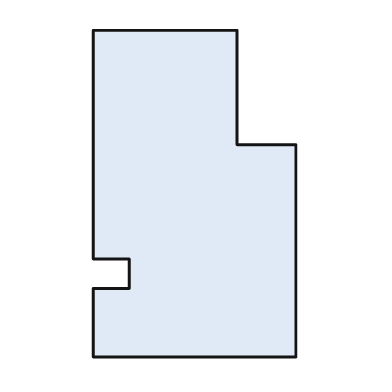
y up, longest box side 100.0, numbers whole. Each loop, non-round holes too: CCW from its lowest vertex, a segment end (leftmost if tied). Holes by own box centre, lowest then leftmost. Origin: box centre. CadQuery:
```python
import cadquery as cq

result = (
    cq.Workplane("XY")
    .moveTo(-31.0, -50.0)
    .lineTo(31.0, -50.0)
    .lineTo(31.0, 15.0)
    .lineTo(13.0, 15.0)
    .lineTo(13.0, 50.0)
    .lineTo(-31.0, 50.0)
    .lineTo(-31.0, -20.0)
    .lineTo(-20.0, -20.0)
    .lineTo(-20.0, -29.0)
    .lineTo(-31.0, -29.0)
    .close()
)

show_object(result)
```